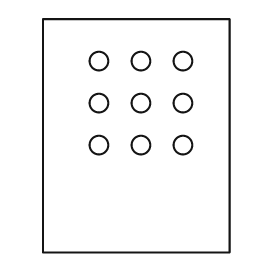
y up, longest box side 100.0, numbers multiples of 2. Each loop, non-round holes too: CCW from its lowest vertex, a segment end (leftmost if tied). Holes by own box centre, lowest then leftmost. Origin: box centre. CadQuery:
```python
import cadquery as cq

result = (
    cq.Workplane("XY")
    .moveTo(-40.0, -50.0)
    .lineTo(40.0, -50.0)
    .lineTo(40.0, 50.0)
    .lineTo(-40.0, 50.0)
    .close()
    .moveTo(-16.0, -4.0)
    .circle(4.0)
    .moveTo(2.0, -4.0)
    .circle(4.0)
    .moveTo(20.0, -4.0)
    .circle(4.0)
    .moveTo(-16.0, 14.0)
    .circle(4.0)
    .moveTo(2.0, 14.0)
    .circle(4.0)
    .moveTo(20.0, 14.0)
    .circle(4.0)
    .moveTo(-16.0, 32.0)
    .circle(4.0)
    .moveTo(2.0, 32.0)
    .circle(4.0)
    .moveTo(20.0, 32.0)
    .circle(4.0)
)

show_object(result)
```